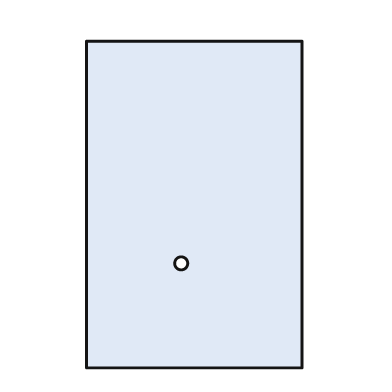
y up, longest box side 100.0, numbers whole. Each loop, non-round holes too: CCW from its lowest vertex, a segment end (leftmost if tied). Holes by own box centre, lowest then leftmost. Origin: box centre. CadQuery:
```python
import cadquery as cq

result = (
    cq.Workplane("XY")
    .moveTo(-33.0, -50.0)
    .lineTo(33.0, -50.0)
    .lineTo(33.0, 50.0)
    .lineTo(-33.0, 50.0)
    .close()
    .moveTo(-4.0, -18.0)
    .circle(2.0)
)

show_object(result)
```